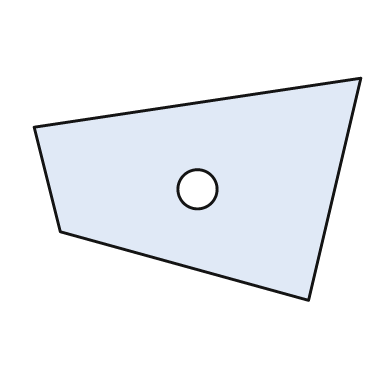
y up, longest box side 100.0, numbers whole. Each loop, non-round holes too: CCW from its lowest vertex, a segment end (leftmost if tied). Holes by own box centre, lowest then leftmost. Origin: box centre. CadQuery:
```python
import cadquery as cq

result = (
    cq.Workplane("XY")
    .moveTo(34.0, -34.0)
    .lineTo(50.0, 34.0)
    .lineTo(-50.0, 19.0)
    .lineTo(-42.0, -13.0)
    .close()
    .moveTo(0.0, 0.0)
    .circle(6.0)
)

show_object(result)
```